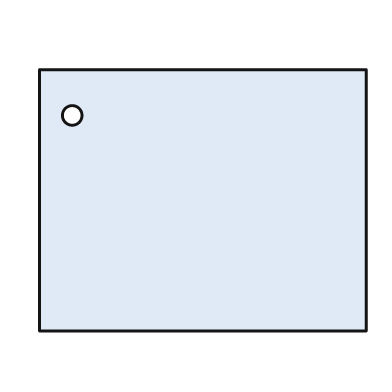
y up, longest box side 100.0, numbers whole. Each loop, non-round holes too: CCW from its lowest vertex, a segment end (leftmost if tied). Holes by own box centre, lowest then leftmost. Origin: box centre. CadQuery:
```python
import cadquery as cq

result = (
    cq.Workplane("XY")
    .moveTo(-50.0, -40.0)
    .lineTo(50.0, -40.0)
    .lineTo(50.0, 40.0)
    .lineTo(-50.0, 40.0)
    .close()
    .moveTo(-40.0, 26.0)
    .circle(3.0)
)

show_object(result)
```